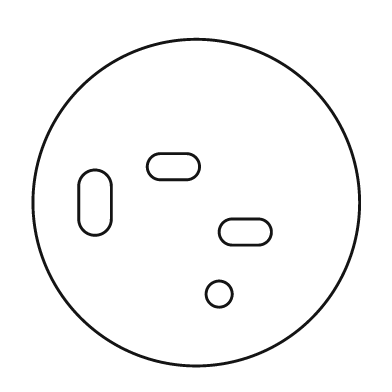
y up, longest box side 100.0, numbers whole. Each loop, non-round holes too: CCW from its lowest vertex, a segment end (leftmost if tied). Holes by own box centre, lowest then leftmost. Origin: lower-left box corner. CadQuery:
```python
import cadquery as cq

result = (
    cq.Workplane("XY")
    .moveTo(50.0, 50.0)
    .circle(50.0)
    .moveTo(57.0, 22.0)
    .circle(4.0)
    .moveTo(61.0, 37.0)
    .lineTo(69.0, 37.0)
    .threePointArc((73.0, 41.0), (69.0, 45.0))
    .lineTo(61.0, 45.0)
    .threePointArc((57.0, 41.0), (61.0, 37.0))
    .close()
    .moveTo(14.0, 45.0)
    .threePointArc((19.0, 40.0), (24.0, 45.0))
    .lineTo(24.0, 55.0)
    .threePointArc((19.0, 60.0), (14.0, 55.0))
    .close()
    .moveTo(39.0, 57.0)
    .lineTo(47.0, 57.0)
    .threePointArc((51.0, 61.0), (47.0, 65.0))
    .lineTo(39.0, 65.0)
    .threePointArc((35.0, 61.0), (39.0, 57.0))
    .close()
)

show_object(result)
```